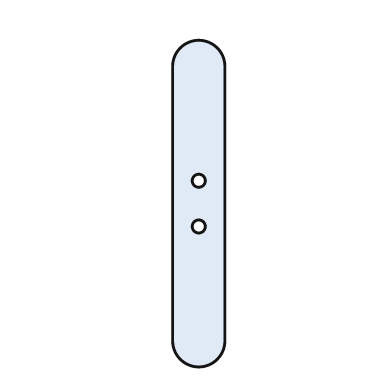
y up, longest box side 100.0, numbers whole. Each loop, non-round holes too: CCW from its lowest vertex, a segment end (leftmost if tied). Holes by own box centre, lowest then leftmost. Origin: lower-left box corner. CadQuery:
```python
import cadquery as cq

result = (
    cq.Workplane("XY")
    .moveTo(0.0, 8.0)
    .threePointArc((8.0, 0.0), (16.0, 8.0))
    .lineTo(16.0, 92.0)
    .threePointArc((8.0, 100.0), (0.0, 92.0))
    .close()
    .moveTo(8.0, 43.0)
    .circle(2.0)
    .moveTo(8.0, 57.0)
    .circle(2.0)
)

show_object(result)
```